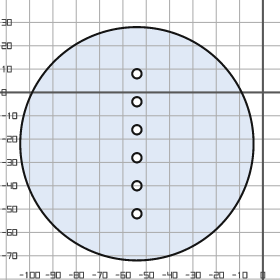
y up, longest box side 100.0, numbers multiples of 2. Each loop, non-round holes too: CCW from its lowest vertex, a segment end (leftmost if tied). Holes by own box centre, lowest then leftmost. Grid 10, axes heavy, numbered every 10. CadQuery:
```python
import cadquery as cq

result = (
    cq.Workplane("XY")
    .moveTo(-54.0, -22.0)
    .circle(50.0)
    .moveTo(-54.0, -52.0)
    .circle(2.0)
    .moveTo(-54.0, -40.0)
    .circle(2.0)
    .moveTo(-54.0, -28.0)
    .circle(2.0)
    .moveTo(-54.0, -16.0)
    .circle(2.0)
    .moveTo(-54.0, -4.0)
    .circle(2.0)
    .moveTo(-54.0, 8.0)
    .circle(2.0)
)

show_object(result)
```